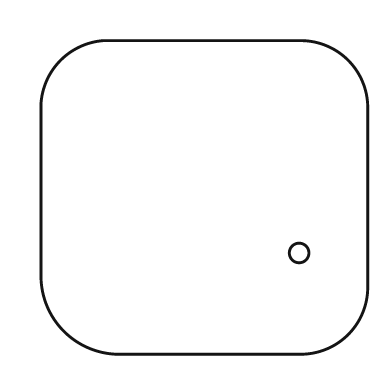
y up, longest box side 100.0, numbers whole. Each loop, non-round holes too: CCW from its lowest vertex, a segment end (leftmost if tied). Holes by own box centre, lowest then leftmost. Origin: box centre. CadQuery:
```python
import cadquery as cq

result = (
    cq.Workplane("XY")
    .moveTo(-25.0, -48.0)
    .lineTo(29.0, -48.0)
    .threePointArc((44.0, -42.0), (50.0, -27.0))
    .lineTo(50.0, 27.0)
    .threePointArc((44.0, 42.0), (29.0, 48.0))
    .lineTo(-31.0, 48.0)
    .threePointArc((-44.0, 42.0), (-50.0, 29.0))
    .lineTo(-50.0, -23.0)
    .threePointArc((-43.0, -41.0), (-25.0, -48.0))
    .close()
    .moveTo(29.0, -17.0)
    .circle(3.0)
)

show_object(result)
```